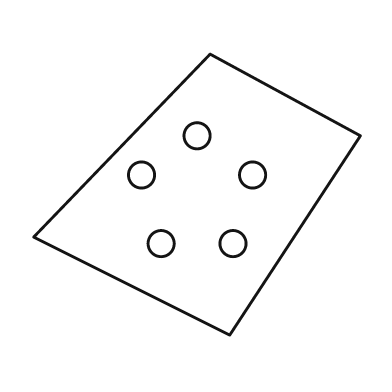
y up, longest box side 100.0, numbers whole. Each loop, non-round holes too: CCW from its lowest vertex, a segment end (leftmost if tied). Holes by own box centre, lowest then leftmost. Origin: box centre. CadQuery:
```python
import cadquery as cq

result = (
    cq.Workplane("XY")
    .moveTo(10.0, -43.0)
    .lineTo(50.0, 18.0)
    .lineTo(4.0, 43.0)
    .lineTo(-50.0, -13.0)
    .close()
    .moveTo(-11.0, -15.0)
    .circle(4.0)
    .moveTo(11.0, -15.0)
    .circle(4.0)
    .moveTo(-17.0, 6.0)
    .circle(4.0)
    .moveTo(17.0, 6.0)
    .circle(4.0)
    .moveTo(0.0, 18.0)
    .circle(4.0)
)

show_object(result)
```